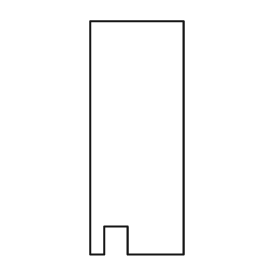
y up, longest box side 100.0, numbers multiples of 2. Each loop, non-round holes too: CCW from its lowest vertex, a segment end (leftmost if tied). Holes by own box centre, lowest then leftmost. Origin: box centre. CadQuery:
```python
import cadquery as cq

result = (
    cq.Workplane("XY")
    .moveTo(-20.0, -50.0)
    .lineTo(-14.0, -50.0)
    .lineTo(-14.0, -38.0)
    .lineTo(-4.0, -38.0)
    .lineTo(-4.0, -50.0)
    .lineTo(20.0, -50.0)
    .lineTo(20.0, 50.0)
    .lineTo(-20.0, 50.0)
    .close()
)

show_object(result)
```